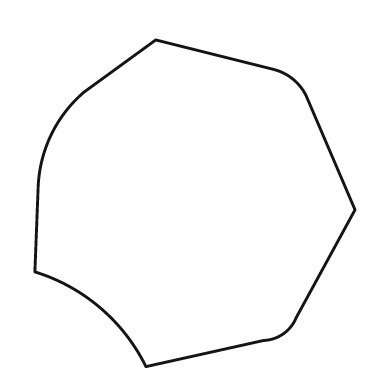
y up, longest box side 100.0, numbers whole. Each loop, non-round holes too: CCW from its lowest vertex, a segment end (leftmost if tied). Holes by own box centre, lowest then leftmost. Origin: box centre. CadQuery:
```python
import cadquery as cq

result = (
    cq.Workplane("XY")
    .moveTo(-15.0, -50.0)
    .lineTo(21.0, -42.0)
    .threePointArc((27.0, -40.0), (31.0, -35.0))
    .lineTo(49.0, -2.0)
    .lineTo(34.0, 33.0)
    .threePointArc((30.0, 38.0), (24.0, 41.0))
    .lineTo(-12.0, 50.0)
    .lineTo(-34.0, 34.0)
    .threePointArc((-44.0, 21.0), (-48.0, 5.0))
    .lineTo(-49.0, -21.0)
    .threePointArc((-29.0, -32.0), (-15.0, -50.0))
    .close()
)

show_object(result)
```